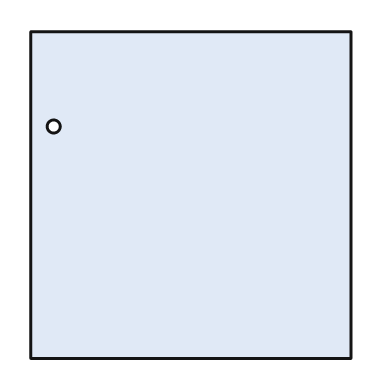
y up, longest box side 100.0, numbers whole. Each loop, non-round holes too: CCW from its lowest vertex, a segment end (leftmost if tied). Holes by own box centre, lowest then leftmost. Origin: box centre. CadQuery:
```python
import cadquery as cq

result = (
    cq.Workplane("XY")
    .moveTo(-49.0, -50.0)
    .lineTo(49.0, -50.0)
    .lineTo(49.0, 50.0)
    .lineTo(-49.0, 50.0)
    .close()
    .moveTo(-42.0, 21.0)
    .circle(2.0)
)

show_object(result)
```